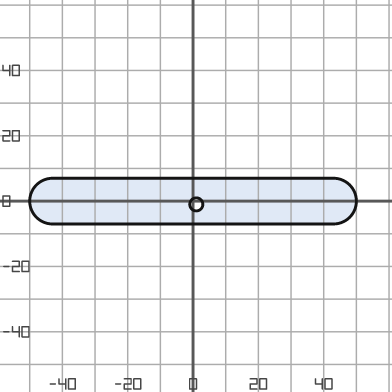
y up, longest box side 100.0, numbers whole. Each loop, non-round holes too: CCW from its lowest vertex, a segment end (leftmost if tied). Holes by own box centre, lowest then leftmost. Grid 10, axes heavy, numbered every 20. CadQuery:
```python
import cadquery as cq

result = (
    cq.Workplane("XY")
    .moveTo(-43.0, -7.0)
    .lineTo(43.0, -7.0)
    .threePointArc((50.0, 0.0), (43.0, 7.0))
    .lineTo(-43.0, 7.0)
    .threePointArc((-50.0, 0.0), (-43.0, -7.0))
    .close()
    .moveTo(1.0, -1.0)
    .circle(2.0)
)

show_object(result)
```